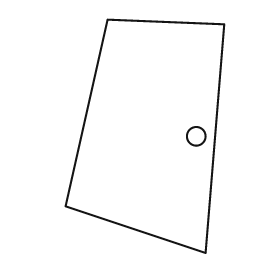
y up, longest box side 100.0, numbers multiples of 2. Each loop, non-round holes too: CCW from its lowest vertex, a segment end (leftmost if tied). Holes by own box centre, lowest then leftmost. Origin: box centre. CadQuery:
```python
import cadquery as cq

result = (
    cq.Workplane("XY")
    .moveTo(26.0, -50.0)
    .lineTo(34.0, 48.0)
    .lineTo(-16.0, 50.0)
    .lineTo(-34.0, -30.0)
    .close()
    .moveTo(22.0, 0.0)
    .circle(4.0)
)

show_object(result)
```